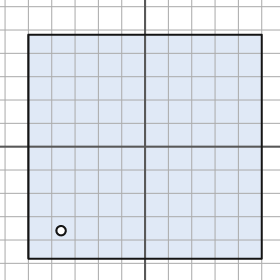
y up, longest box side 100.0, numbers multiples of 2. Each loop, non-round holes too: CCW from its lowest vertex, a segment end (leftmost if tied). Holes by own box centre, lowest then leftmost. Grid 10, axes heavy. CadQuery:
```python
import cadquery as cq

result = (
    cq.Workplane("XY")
    .moveTo(-50.0, -48.0)
    .lineTo(50.0, -48.0)
    .lineTo(50.0, 48.0)
    .lineTo(-50.0, 48.0)
    .close()
    .moveTo(-36.0, -36.0)
    .circle(2.0)
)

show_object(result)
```